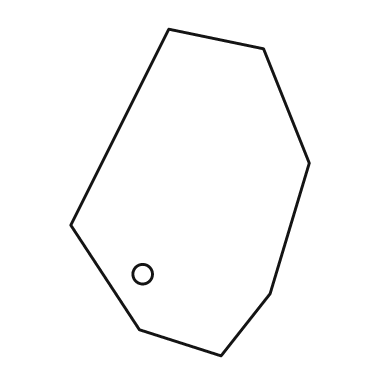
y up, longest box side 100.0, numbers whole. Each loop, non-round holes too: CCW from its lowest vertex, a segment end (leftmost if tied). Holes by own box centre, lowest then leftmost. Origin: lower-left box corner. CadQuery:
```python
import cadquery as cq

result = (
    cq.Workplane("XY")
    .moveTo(46.0, 0.0)
    .lineTo(61.0, 19.0)
    .lineTo(73.0, 59.0)
    .lineTo(59.0, 94.0)
    .lineTo(30.0, 100.0)
    .lineTo(0.0, 40.0)
    .lineTo(21.0, 8.0)
    .close()
    .moveTo(22.0, 25.0)
    .circle(3.0)
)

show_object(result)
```